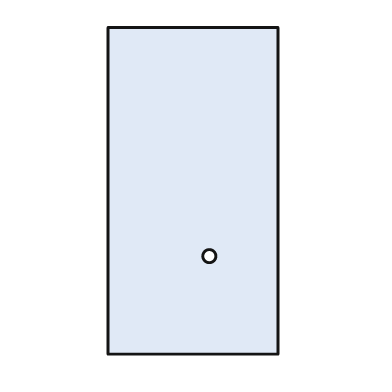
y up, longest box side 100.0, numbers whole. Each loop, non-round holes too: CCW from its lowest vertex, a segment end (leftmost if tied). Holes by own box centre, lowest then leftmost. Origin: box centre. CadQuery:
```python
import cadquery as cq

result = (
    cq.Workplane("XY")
    .moveTo(-26.0, -50.0)
    .lineTo(26.0, -50.0)
    .lineTo(26.0, 50.0)
    .lineTo(-26.0, 50.0)
    .close()
    .moveTo(5.0, -20.0)
    .circle(2.0)
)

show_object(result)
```